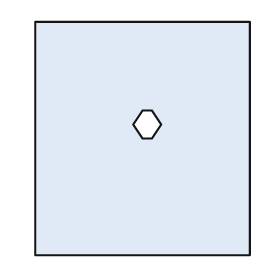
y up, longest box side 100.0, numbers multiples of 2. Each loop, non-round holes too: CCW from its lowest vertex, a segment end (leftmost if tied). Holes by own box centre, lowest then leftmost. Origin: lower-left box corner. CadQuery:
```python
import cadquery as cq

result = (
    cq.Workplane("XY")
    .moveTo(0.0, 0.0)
    .lineTo(92.0, 0.0)
    .lineTo(92.0, 100.0)
    .lineTo(0.0, 100.0)
    .close()
    .moveTo(46.0, 50.0)
    .lineTo(50.0, 50.0)
    .lineTo(54.0, 56.0)
    .lineTo(50.0, 62.0)
    .lineTo(46.0, 62.0)
    .lineTo(42.0, 56.0)
    .close()
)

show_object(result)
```